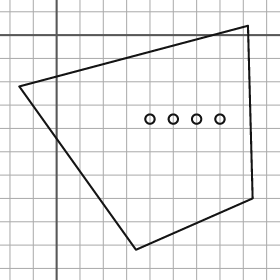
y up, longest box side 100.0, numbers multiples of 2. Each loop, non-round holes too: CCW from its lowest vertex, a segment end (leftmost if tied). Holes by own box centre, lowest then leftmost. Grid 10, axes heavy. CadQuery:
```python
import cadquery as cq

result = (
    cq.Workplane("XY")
    .moveTo(34.0, -92.0)
    .lineTo(84.0, -70.0)
    .lineTo(82.0, 4.0)
    .lineTo(-16.0, -22.0)
    .close()
    .moveTo(40.0, -36.0)
    .circle(2.0)
    .moveTo(50.0, -36.0)
    .circle(2.0)
    .moveTo(60.0, -36.0)
    .circle(2.0)
    .moveTo(70.0, -36.0)
    .circle(2.0)
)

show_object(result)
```